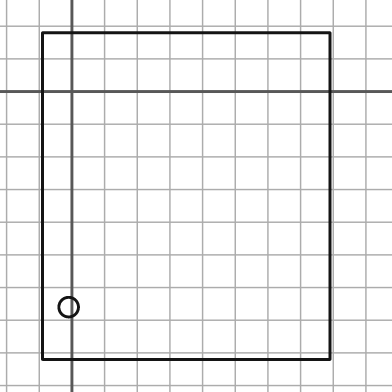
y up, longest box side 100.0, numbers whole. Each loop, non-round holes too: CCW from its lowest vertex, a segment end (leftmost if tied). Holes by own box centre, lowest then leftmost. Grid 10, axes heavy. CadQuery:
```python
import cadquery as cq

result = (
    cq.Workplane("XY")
    .moveTo(-9.0, -82.0)
    .lineTo(79.0, -82.0)
    .lineTo(79.0, 18.0)
    .lineTo(-9.0, 18.0)
    .close()
    .moveTo(-1.0, -66.0)
    .circle(3.0)
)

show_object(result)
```